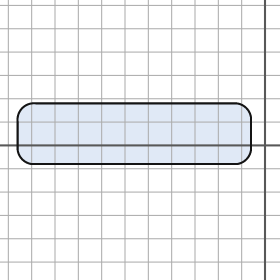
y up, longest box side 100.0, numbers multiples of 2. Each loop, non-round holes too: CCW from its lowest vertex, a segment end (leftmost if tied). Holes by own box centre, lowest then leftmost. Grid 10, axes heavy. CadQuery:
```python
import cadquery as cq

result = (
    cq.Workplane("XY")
    .moveTo(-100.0, -8.0)
    .lineTo(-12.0, -8.0)
    .threePointArc((-8.0, -6.0), (-6.0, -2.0))
    .lineTo(-6.0, 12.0)
    .threePointArc((-8.0, 16.0), (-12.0, 18.0))
    .lineTo(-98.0, 18.0)
    .threePointArc((-104.0, 16.0), (-106.0, 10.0))
    .lineTo(-106.0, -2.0)
    .threePointArc((-104.0, -6.0), (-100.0, -8.0))
    .close()
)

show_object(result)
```